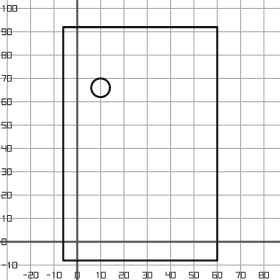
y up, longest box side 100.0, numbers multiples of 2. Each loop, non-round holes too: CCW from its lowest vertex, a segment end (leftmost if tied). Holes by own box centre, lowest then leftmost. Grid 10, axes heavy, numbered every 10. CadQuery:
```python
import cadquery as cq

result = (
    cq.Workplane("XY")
    .moveTo(-6.0, -8.0)
    .lineTo(60.0, -8.0)
    .lineTo(60.0, 92.0)
    .lineTo(-6.0, 92.0)
    .close()
    .moveTo(10.0, 66.0)
    .circle(4.0)
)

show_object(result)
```